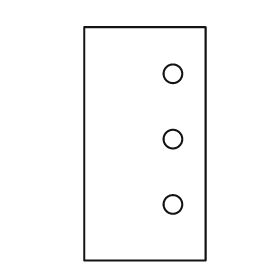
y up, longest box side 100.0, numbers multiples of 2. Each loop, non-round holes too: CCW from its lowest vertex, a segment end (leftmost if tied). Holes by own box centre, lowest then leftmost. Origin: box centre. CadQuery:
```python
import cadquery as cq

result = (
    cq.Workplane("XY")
    .moveTo(-26.0, -50.0)
    .lineTo(26.0, -50.0)
    .lineTo(26.0, 50.0)
    .lineTo(-26.0, 50.0)
    .close()
    .moveTo(12.0, -26.0)
    .circle(4.0)
    .moveTo(12.0, 2.0)
    .circle(4.0)
    .moveTo(12.0, 30.0)
    .circle(4.0)
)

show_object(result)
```